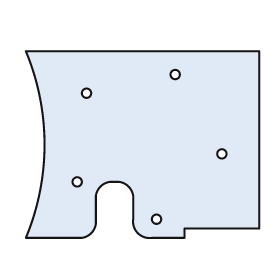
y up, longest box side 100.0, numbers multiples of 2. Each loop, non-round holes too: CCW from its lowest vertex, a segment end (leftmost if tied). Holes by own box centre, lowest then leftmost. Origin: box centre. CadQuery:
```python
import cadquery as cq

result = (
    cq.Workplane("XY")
    .moveTo(-50.0, -40.0)
    .lineTo(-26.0, -40.0)
    .threePointArc((-22.0, -38.0), (-20.0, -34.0))
    .lineTo(-20.0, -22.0)
    .threePointArc((-18.0, -18.0), (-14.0, -16.0))
    .lineTo(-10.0, -16.0)
    .threePointArc((-6.0, -18.0), (-4.0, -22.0))
    .lineTo(-4.0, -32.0)
    .threePointArc((-2.0, -38.0), (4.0, -40.0))
    .lineTo(18.0, -40.0)
    .lineTo(18.0, -36.0)
    .lineTo(50.0, -36.0)
    .lineTo(50.0, 40.0)
    .lineTo(-50.0, 40.0)
    .threePointArc((-42.0, 0.0), (-50.0, -40.0))
    .close()
    .moveTo(6.0, -32.0)
    .circle(2.0)
    .moveTo(-28.0, -16.0)
    .circle(2.0)
    .moveTo(34.0, -4.0)
    .circle(2.0)
    .moveTo(-24.0, 22.0)
    .circle(2.0)
    .moveTo(14.0, 30.0)
    .circle(2.0)
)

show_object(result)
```